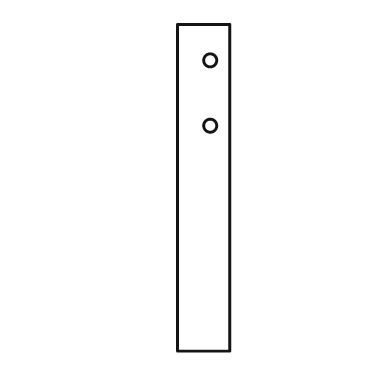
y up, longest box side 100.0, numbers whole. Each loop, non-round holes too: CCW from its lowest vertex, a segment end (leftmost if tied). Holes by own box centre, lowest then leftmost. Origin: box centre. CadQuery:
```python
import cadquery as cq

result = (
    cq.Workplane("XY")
    .moveTo(-8.0, -50.0)
    .lineTo(8.0, -50.0)
    .lineTo(8.0, 50.0)
    .lineTo(-8.0, 50.0)
    .close()
    .moveTo(2.0, 19.0)
    .circle(2.0)
    .moveTo(2.0, 39.0)
    .circle(2.0)
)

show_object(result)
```